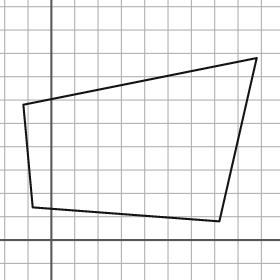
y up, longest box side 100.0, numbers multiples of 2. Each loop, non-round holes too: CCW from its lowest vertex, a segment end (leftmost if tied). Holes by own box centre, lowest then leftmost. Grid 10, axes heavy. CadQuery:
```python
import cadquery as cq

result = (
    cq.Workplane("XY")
    .moveTo(72.0, 8.0)
    .lineTo(88.0, 78.0)
    .lineTo(-12.0, 58.0)
    .lineTo(-8.0, 14.0)
    .close()
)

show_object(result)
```